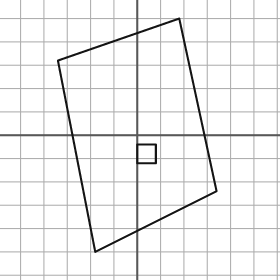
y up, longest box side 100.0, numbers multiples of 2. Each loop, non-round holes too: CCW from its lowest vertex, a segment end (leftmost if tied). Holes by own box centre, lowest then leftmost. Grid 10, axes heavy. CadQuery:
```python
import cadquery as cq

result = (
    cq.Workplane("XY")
    .moveTo(-18.0, -50.0)
    .lineTo(34.0, -24.0)
    .lineTo(18.0, 50.0)
    .lineTo(-34.0, 32.0)
    .close()
    .moveTo(0.0, -12.0)
    .lineTo(8.0, -12.0)
    .lineTo(8.0, -4.0)
    .lineTo(0.0, -4.0)
    .close()
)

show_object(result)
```